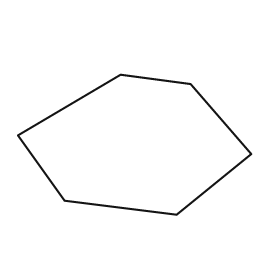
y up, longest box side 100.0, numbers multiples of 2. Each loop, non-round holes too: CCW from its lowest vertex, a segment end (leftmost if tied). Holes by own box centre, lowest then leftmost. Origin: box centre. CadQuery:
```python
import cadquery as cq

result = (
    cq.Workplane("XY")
    .moveTo(18.0, -30.0)
    .lineTo(50.0, -4.0)
    .lineTo(24.0, 26.0)
    .lineTo(-6.0, 30.0)
    .lineTo(-50.0, 4.0)
    .lineTo(-30.0, -24.0)
    .close()
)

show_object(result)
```